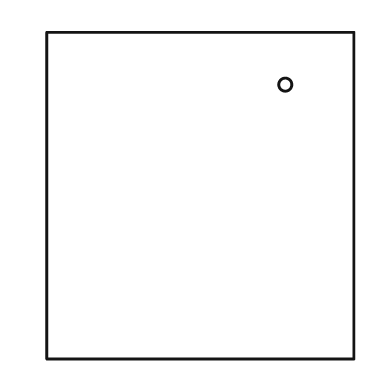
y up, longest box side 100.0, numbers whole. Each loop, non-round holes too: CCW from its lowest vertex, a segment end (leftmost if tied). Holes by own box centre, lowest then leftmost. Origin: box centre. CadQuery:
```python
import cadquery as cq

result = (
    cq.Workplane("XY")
    .moveTo(-47.0, -50.0)
    .lineTo(47.0, -50.0)
    .lineTo(47.0, 50.0)
    .lineTo(-47.0, 50.0)
    .close()
    .moveTo(26.0, 34.0)
    .circle(2.0)
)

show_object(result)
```